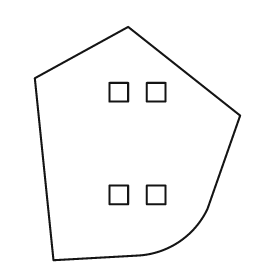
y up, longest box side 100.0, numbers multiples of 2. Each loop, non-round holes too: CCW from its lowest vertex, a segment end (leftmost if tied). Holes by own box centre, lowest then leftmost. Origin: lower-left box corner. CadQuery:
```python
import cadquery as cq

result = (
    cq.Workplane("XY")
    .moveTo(8.0, 0.0)
    .lineTo(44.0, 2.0)
    .threePointArc((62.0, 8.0), (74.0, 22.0))
    .lineTo(88.0, 62.0)
    .lineTo(40.0, 100.0)
    .lineTo(0.0, 78.0)
    .close()
    .moveTo(32.0, 24.0)
    .lineTo(40.0, 24.0)
    .lineTo(40.0, 32.0)
    .lineTo(32.0, 32.0)
    .close()
    .moveTo(48.0, 24.0)
    .lineTo(56.0, 24.0)
    .lineTo(56.0, 32.0)
    .lineTo(48.0, 32.0)
    .close()
    .moveTo(32.0, 68.0)
    .lineTo(40.0, 68.0)
    .lineTo(40.0, 76.0)
    .lineTo(32.0, 76.0)
    .close()
    .moveTo(48.0, 68.0)
    .lineTo(56.0, 68.0)
    .lineTo(56.0, 76.0)
    .lineTo(48.0, 76.0)
    .close()
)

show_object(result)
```